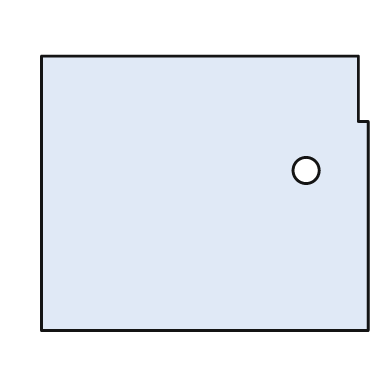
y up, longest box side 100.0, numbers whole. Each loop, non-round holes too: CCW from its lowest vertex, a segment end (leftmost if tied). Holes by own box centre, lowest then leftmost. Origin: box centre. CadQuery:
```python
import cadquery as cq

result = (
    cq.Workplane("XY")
    .moveTo(-50.0, -42.0)
    .lineTo(50.0, -42.0)
    .lineTo(50.0, 22.0)
    .lineTo(47.0, 22.0)
    .lineTo(47.0, 42.0)
    .lineTo(-50.0, 42.0)
    .close()
    .moveTo(31.0, 7.0)
    .circle(4.0)
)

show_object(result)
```